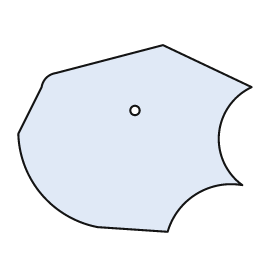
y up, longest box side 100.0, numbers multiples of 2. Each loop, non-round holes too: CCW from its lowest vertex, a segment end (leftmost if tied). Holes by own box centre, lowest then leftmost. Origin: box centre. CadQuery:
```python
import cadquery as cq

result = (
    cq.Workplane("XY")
    .moveTo(14.0, -40.0)
    .threePointArc((26.0, -24.0), (46.0, -20.0))
    .threePointArc((36.0, 2.0), (50.0, 22.0))
    .lineTo(12.0, 40.0)
    .lineTo(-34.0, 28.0)
    .threePointArc((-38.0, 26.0), (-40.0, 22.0))
    .lineTo(-50.0, 2.0)
    .threePointArc((-40.0, -24.0), (-16.0, -38.0))
    .close()
    .moveTo(0.0, 12.0)
    .circle(2.0)
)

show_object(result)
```